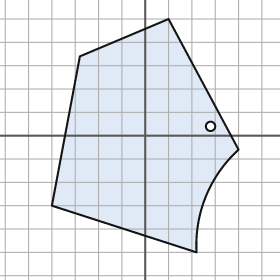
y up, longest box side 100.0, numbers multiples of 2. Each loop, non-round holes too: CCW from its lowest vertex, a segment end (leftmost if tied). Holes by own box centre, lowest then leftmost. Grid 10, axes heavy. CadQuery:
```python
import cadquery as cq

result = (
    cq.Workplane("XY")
    .moveTo(22.0, -50.0)
    .threePointArc((26.0, -26.0), (40.0, -6.0))
    .lineTo(10.0, 50.0)
    .lineTo(-28.0, 34.0)
    .lineTo(-40.0, -30.0)
    .close()
    .moveTo(28.0, 4.0)
    .circle(2.0)
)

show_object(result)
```